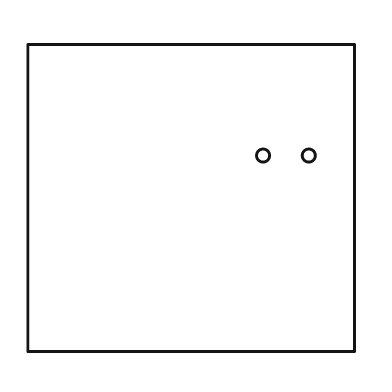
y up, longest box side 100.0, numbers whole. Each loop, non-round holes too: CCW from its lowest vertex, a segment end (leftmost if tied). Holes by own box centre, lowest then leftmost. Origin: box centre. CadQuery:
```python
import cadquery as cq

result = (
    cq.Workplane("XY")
    .moveTo(-50.0, -47.0)
    .lineTo(50.0, -47.0)
    .lineTo(50.0, 47.0)
    .lineTo(-50.0, 47.0)
    .close()
    .moveTo(22.0, 13.0)
    .circle(2.0)
    .moveTo(36.0, 13.0)
    .circle(2.0)
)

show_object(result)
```